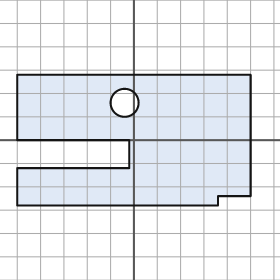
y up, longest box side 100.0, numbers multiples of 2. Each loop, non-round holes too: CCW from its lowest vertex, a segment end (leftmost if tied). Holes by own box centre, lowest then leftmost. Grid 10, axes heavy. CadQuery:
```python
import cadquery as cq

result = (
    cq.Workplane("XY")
    .moveTo(-50.0, -28.0)
    .lineTo(36.0, -28.0)
    .lineTo(36.0, -24.0)
    .lineTo(50.0, -24.0)
    .lineTo(50.0, 28.0)
    .lineTo(-50.0, 28.0)
    .lineTo(-50.0, 0.0)
    .lineTo(-2.0, 0.0)
    .lineTo(-2.0, -12.0)
    .lineTo(-50.0, -12.0)
    .close()
    .moveTo(-4.0, 16.0)
    .circle(6.0)
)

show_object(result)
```